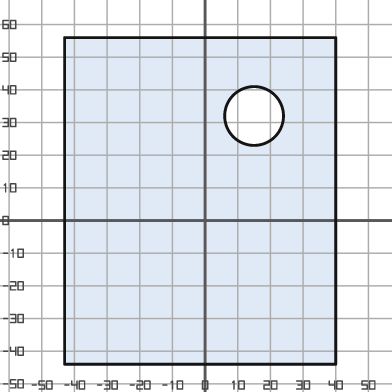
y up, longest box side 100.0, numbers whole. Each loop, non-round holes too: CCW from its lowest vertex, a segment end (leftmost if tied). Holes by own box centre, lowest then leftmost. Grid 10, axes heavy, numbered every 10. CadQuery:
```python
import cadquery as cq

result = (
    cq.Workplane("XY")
    .moveTo(-43.0, -44.0)
    .lineTo(40.0, -44.0)
    .lineTo(40.0, 56.0)
    .lineTo(-43.0, 56.0)
    .close()
    .moveTo(15.0, 32.0)
    .circle(9.0)
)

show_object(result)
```